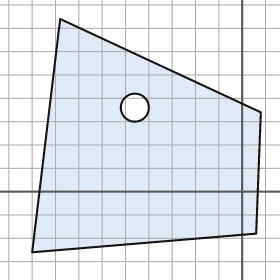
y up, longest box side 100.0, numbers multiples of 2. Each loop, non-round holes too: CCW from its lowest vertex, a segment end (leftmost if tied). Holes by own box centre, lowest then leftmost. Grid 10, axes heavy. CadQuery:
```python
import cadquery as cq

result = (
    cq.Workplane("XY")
    .moveTo(-90.0, -26.0)
    .lineTo(6.0, -18.0)
    .lineTo(8.0, 34.0)
    .lineTo(-78.0, 74.0)
    .close()
    .moveTo(-46.0, 36.0)
    .circle(6.0)
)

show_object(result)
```